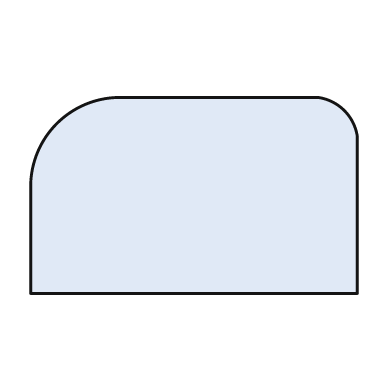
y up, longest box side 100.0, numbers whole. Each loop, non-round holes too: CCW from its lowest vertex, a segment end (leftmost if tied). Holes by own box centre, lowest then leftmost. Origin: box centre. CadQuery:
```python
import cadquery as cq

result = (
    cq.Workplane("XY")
    .moveTo(-50.0, -30.0)
    .lineTo(50.0, -30.0)
    .lineTo(50.0, 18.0)
    .threePointArc((46.0, 26.0), (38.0, 30.0))
    .lineTo(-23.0, 30.0)
    .threePointArc((-42.0, 22.0), (-50.0, 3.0))
    .close()
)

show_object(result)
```